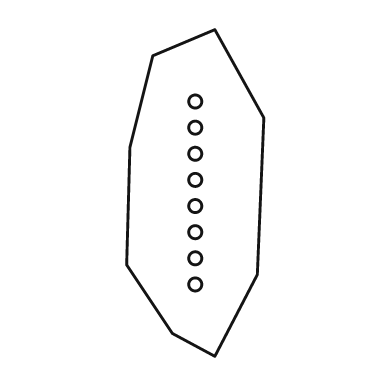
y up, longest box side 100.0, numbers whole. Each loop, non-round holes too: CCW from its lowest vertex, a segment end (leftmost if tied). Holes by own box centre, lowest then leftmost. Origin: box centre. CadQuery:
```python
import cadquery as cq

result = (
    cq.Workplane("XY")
    .moveTo(6.0, -50.0)
    .lineTo(19.0, -25.0)
    .lineTo(21.0, 23.0)
    .lineTo(6.0, 50.0)
    .lineTo(-13.0, 42.0)
    .lineTo(-20.0, 14.0)
    .lineTo(-21.0, -22.0)
    .lineTo(-7.0, -43.0)
    .close()
    .moveTo(0.0, -28.0)
    .circle(2.0)
    .moveTo(0.0, -20.0)
    .circle(2.0)
    .moveTo(0.0, -12.0)
    .circle(2.0)
    .moveTo(0.0, -4.0)
    .circle(2.0)
    .moveTo(0.0, 4.0)
    .circle(2.0)
    .moveTo(0.0, 12.0)
    .circle(2.0)
    .moveTo(0.0, 20.0)
    .circle(2.0)
    .moveTo(0.0, 28.0)
    .circle(2.0)
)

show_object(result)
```